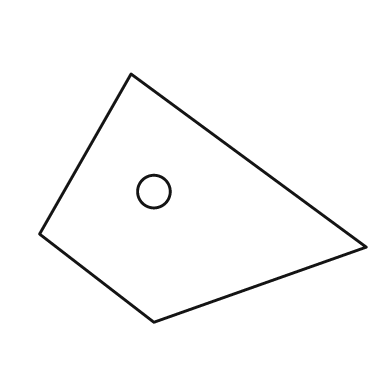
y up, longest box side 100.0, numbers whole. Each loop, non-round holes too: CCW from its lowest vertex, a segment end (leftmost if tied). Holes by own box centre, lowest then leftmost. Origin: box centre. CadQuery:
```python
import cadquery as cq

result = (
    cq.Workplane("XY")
    .moveTo(-15.0, -38.0)
    .lineTo(50.0, -15.0)
    .lineTo(-22.0, 38.0)
    .lineTo(-50.0, -11.0)
    .close()
    .moveTo(-15.0, 2.0)
    .circle(5.0)
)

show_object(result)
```